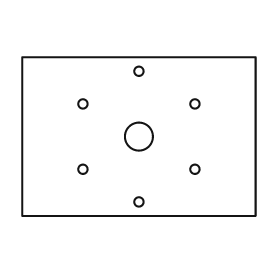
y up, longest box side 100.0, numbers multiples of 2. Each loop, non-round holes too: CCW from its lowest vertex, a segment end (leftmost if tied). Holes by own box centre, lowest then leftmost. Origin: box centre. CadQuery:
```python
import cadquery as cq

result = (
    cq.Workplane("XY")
    .moveTo(-50.0, -34.0)
    .lineTo(50.0, -34.0)
    .lineTo(50.0, 34.0)
    .lineTo(-50.0, 34.0)
    .close()
    .moveTo(0.0, -28.0)
    .circle(2.0)
    .moveTo(-24.0, -14.0)
    .circle(2.0)
    .moveTo(24.0, -14.0)
    .circle(2.0)
    .moveTo(0.0, 0.0)
    .circle(6.0)
    .moveTo(-24.0, 14.0)
    .circle(2.0)
    .moveTo(24.0, 14.0)
    .circle(2.0)
    .moveTo(0.0, 28.0)
    .circle(2.0)
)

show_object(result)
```